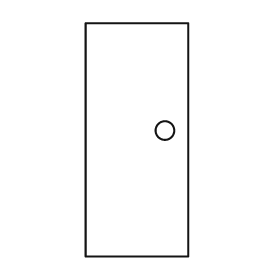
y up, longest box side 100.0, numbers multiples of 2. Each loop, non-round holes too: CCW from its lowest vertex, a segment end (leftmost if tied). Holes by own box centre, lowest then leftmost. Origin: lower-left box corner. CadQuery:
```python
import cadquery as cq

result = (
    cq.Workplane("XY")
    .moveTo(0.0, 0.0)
    .lineTo(44.0, 0.0)
    .lineTo(44.0, 100.0)
    .lineTo(0.0, 100.0)
    .close()
    .moveTo(34.0, 54.0)
    .circle(4.0)
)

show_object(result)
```